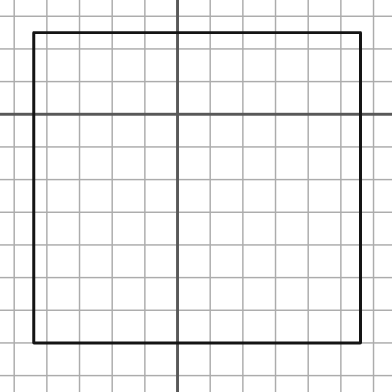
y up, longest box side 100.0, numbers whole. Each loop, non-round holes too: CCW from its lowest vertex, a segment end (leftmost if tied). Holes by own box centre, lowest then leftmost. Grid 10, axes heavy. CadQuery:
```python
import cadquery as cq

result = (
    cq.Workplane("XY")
    .moveTo(-44.0, -70.0)
    .lineTo(56.0, -70.0)
    .lineTo(56.0, 25.0)
    .lineTo(-44.0, 25.0)
    .close()
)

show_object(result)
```